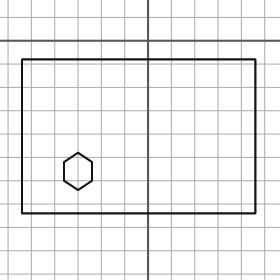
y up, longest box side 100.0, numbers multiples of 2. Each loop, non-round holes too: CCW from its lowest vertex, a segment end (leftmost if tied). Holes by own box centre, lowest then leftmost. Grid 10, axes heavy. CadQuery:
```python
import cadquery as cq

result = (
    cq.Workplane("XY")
    .moveTo(-54.0, -74.0)
    .lineTo(46.0, -74.0)
    .lineTo(46.0, -8.0)
    .lineTo(-54.0, -8.0)
    .close()
    .moveTo(-30.0, -64.0)
    .lineTo(-24.0, -60.0)
    .lineTo(-24.0, -52.0)
    .lineTo(-30.0, -48.0)
    .lineTo(-36.0, -52.0)
    .lineTo(-36.0, -60.0)
    .close()
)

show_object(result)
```